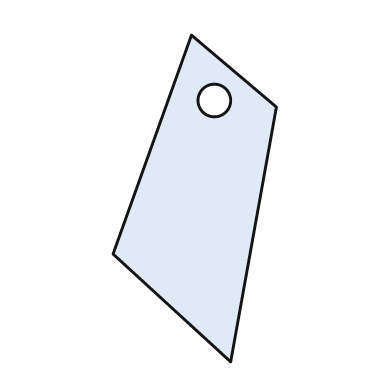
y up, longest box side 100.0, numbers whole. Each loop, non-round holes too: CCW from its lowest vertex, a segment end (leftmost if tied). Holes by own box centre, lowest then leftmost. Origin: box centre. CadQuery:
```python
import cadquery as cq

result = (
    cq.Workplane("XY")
    .moveTo(11.0, -50.0)
    .lineTo(25.0, 28.0)
    .lineTo(-1.0, 50.0)
    .lineTo(-25.0, -17.0)
    .close()
    .moveTo(6.0, 30.0)
    .circle(5.0)
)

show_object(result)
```